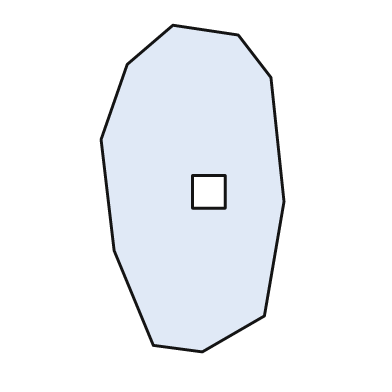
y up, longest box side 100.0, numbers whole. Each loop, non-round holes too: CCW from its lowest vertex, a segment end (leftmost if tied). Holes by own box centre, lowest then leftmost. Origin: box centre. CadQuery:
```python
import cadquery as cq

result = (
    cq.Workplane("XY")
    .moveTo(3.0, -50.0)
    .lineTo(22.0, -39.0)
    .lineTo(28.0, -4.0)
    .lineTo(24.0, 34.0)
    .lineTo(14.0, 47.0)
    .lineTo(-6.0, 50.0)
    .lineTo(-20.0, 38.0)
    .lineTo(-28.0, 15.0)
    .lineTo(-24.0, -19.0)
    .lineTo(-12.0, -48.0)
    .close()
    .moveTo(0.0, -6.0)
    .lineTo(10.0, -6.0)
    .lineTo(10.0, 4.0)
    .lineTo(0.0, 4.0)
    .close()
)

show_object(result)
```